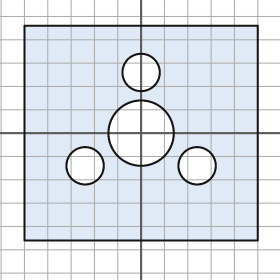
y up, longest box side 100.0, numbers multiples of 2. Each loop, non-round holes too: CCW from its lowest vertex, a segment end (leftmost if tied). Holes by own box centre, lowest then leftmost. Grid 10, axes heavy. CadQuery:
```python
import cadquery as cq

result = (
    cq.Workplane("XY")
    .moveTo(-50.0, -46.0)
    .lineTo(50.0, -46.0)
    .lineTo(50.0, 46.0)
    .lineTo(-50.0, 46.0)
    .close()
    .moveTo(-24.0, -14.0)
    .circle(8.0)
    .moveTo(24.0, -14.0)
    .circle(8.0)
    .moveTo(0.0, 0.0)
    .circle(14.0)
    .moveTo(0.0, 26.0)
    .circle(8.0)
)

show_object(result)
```